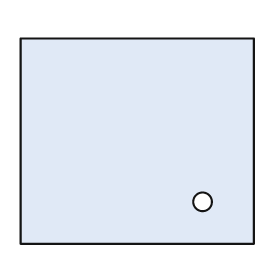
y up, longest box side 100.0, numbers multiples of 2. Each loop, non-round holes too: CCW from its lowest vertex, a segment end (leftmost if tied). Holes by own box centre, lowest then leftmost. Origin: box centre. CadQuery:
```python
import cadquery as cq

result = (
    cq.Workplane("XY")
    .moveTo(-50.0, -44.0)
    .lineTo(50.0, -44.0)
    .lineTo(50.0, 44.0)
    .lineTo(-50.0, 44.0)
    .close()
    .moveTo(28.0, -26.0)
    .circle(4.0)
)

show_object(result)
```